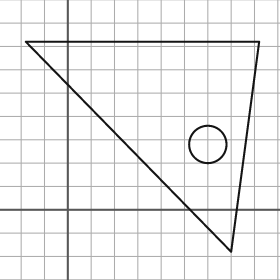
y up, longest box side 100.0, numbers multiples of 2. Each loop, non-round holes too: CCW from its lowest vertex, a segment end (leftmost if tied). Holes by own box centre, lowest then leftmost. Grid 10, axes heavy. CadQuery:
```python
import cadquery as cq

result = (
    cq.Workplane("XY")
    .moveTo(70.0, -18.0)
    .lineTo(82.0, 72.0)
    .lineTo(-18.0, 72.0)
    .close()
    .moveTo(60.0, 28.0)
    .circle(8.0)
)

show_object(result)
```